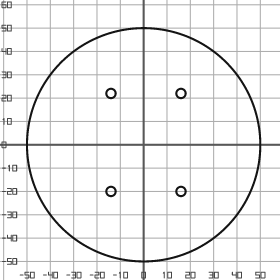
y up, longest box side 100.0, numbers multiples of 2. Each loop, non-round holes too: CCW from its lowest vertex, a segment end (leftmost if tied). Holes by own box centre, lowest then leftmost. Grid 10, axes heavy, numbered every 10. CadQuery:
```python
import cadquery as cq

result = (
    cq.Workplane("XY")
    .moveTo(0.0, 0.0)
    .circle(50.0)
    .moveTo(-14.0, -20.0)
    .circle(2.0)
    .moveTo(16.0, -20.0)
    .circle(2.0)
    .moveTo(-14.0, 22.0)
    .circle(2.0)
    .moveTo(16.0, 22.0)
    .circle(2.0)
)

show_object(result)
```